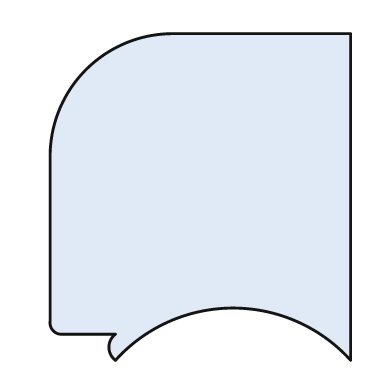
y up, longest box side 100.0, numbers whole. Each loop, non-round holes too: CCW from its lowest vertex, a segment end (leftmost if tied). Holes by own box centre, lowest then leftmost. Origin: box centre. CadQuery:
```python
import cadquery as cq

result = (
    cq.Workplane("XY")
    .moveTo(-26.0, -50.0)
    .threePointArc((10.0, -34.0), (46.0, -50.0))
    .lineTo(46.0, 50.0)
    .lineTo(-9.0, 50.0)
    .threePointArc((-35.0, 39.0), (-46.0, 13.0))
    .lineTo(-46.0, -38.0)
    .threePointArc((-45.0, -41.0), (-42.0, -42.0))
    .lineTo(-26.0, -42.0)
    .threePointArc((-28.0, -46.0), (-26.0, -50.0))
    .close()
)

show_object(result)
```